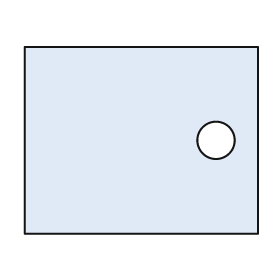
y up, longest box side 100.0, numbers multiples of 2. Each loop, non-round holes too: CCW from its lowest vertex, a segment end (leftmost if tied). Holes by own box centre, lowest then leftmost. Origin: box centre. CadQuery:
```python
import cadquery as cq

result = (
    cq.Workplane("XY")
    .moveTo(-50.0, -40.0)
    .lineTo(50.0, -40.0)
    .lineTo(50.0, 40.0)
    .lineTo(-50.0, 40.0)
    .close()
    .moveTo(32.0, 0.0)
    .circle(8.0)
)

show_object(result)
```